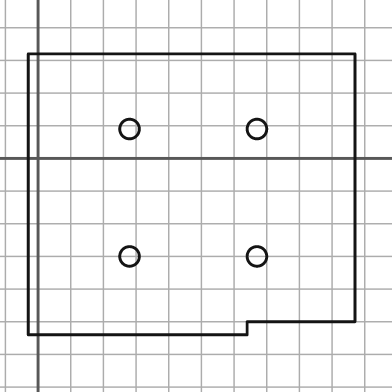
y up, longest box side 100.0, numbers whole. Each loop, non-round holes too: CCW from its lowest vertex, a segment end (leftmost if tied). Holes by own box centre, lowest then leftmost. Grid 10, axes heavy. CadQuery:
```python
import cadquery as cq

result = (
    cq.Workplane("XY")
    .moveTo(-3.0, -54.0)
    .lineTo(64.0, -54.0)
    .lineTo(64.0, -50.0)
    .lineTo(97.0, -50.0)
    .lineTo(97.0, 32.0)
    .lineTo(-3.0, 32.0)
    .close()
    .moveTo(28.0, -30.0)
    .circle(3.0)
    .moveTo(67.0, -30.0)
    .circle(3.0)
    .moveTo(28.0, 9.0)
    .circle(3.0)
    .moveTo(67.0, 9.0)
    .circle(3.0)
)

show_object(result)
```